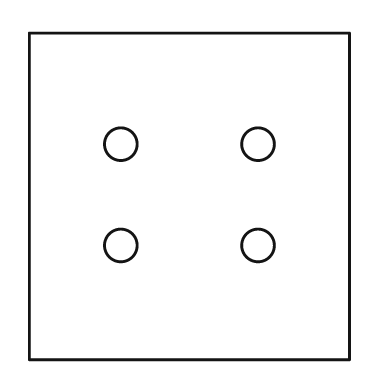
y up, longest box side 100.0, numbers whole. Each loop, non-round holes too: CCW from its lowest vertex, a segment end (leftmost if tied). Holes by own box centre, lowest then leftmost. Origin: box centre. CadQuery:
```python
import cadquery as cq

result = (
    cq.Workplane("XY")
    .moveTo(-49.0, -50.0)
    .lineTo(49.0, -50.0)
    .lineTo(49.0, 50.0)
    .lineTo(-49.0, 50.0)
    .close()
    .moveTo(-21.0, -15.0)
    .circle(5.0)
    .moveTo(21.0, -15.0)
    .circle(5.0)
    .moveTo(-21.0, 16.0)
    .circle(5.0)
    .moveTo(21.0, 16.0)
    .circle(5.0)
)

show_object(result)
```